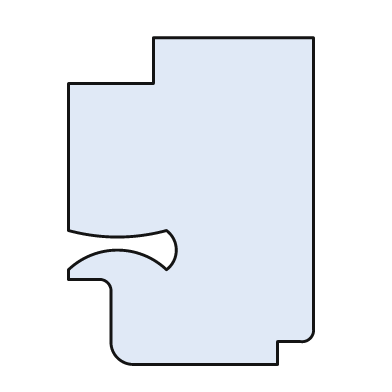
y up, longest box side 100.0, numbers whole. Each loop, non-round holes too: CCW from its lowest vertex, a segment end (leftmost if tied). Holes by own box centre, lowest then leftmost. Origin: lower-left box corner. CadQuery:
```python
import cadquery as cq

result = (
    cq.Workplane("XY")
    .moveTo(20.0, 0.0)
    .lineTo(64.0, 0.0)
    .lineTo(64.0, 7.0)
    .lineTo(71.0, 7.0)
    .threePointArc((74.0, 8.0), (75.0, 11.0))
    .lineTo(75.0, 100.0)
    .lineTo(26.0, 100.0)
    .lineTo(26.0, 86.0)
    .lineTo(0.0, 86.0)
    .lineTo(0.0, 41.0)
    .threePointArc((15.0, 39.0), (30.0, 41.0))
    .threePointArc((33.0, 35.0), (30.0, 29.0))
    .threePointArc((15.0, 35.0), (0.0, 29.0))
    .lineTo(0.0, 26.0)
    .lineTo(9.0, 26.0)
    .threePointArc((12.0, 25.0), (13.0, 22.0))
    .lineTo(13.0, 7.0)
    .threePointArc((15.0, 2.0), (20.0, 0.0))
    .close()
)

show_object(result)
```